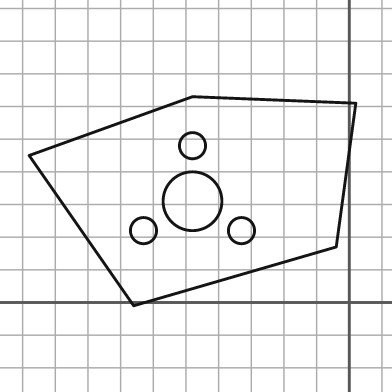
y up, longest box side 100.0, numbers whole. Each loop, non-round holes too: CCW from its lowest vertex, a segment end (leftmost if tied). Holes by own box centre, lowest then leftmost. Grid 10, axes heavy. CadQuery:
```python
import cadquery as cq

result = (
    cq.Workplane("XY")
    .moveTo(-66.0, -1.0)
    .lineTo(-4.0, 17.0)
    .lineTo(2.0, 61.0)
    .lineTo(-48.0, 63.0)
    .lineTo(-98.0, 45.0)
    .close()
    .moveTo(-63.0, 22.0)
    .circle(4.0)
    .moveTo(-33.0, 22.0)
    .circle(4.0)
    .moveTo(-48.0, 31.0)
    .circle(9.0)
    .moveTo(-48.0, 48.0)
    .circle(4.0)
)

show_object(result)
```